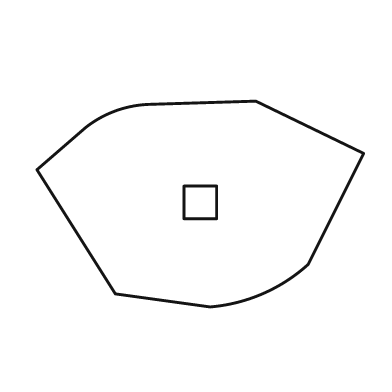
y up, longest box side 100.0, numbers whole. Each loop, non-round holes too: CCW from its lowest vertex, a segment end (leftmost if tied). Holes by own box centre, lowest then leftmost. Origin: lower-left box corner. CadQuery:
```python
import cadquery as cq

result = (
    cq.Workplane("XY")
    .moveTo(53.0, 0.0)
    .threePointArc((69.0, 4.0), (83.0, 13.0))
    .lineTo(100.0, 47.0)
    .lineTo(67.0, 63.0)
    .lineTo(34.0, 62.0)
    .threePointArc((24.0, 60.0), (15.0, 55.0))
    .lineTo(0.0, 42.0)
    .lineTo(24.0, 4.0)
    .close()
    .moveTo(45.0, 27.0)
    .lineTo(55.0, 27.0)
    .lineTo(55.0, 37.0)
    .lineTo(45.0, 37.0)
    .close()
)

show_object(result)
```